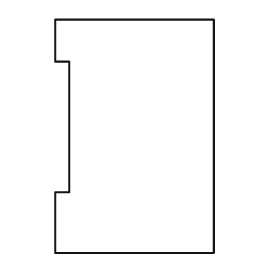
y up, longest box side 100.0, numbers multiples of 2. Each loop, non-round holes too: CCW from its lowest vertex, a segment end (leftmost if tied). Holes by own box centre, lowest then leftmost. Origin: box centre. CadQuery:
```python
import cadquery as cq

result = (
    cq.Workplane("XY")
    .moveTo(-34.0, -50.0)
    .lineTo(34.0, -50.0)
    .lineTo(34.0, 50.0)
    .lineTo(-34.0, 50.0)
    .lineTo(-34.0, 32.0)
    .lineTo(-28.0, 32.0)
    .lineTo(-28.0, -24.0)
    .lineTo(-34.0, -24.0)
    .close()
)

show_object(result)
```